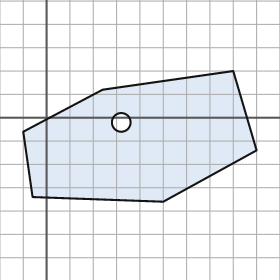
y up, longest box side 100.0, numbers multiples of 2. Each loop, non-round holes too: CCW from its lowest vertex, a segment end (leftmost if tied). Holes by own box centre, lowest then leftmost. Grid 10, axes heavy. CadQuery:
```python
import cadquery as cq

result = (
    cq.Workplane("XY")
    .moveTo(50.0, -36.0)
    .lineTo(90.0, -14.0)
    .lineTo(80.0, 20.0)
    .lineTo(24.0, 12.0)
    .lineTo(-10.0, -6.0)
    .lineTo(-6.0, -34.0)
    .close()
    .moveTo(32.0, -2.0)
    .circle(4.0)
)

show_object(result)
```